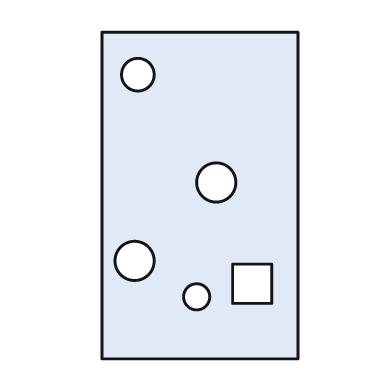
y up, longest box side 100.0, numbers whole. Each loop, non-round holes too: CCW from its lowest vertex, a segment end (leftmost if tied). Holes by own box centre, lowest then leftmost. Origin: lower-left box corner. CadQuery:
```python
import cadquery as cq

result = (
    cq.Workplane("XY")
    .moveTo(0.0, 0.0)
    .lineTo(60.0, 0.0)
    .lineTo(60.0, 100.0)
    .lineTo(0.0, 100.0)
    .close()
    .moveTo(29.0, 19.0)
    .circle(4.0)
    .moveTo(40.0, 17.0)
    .lineTo(52.0, 17.0)
    .lineTo(52.0, 29.0)
    .lineTo(40.0, 29.0)
    .close()
    .moveTo(10.0, 30.0)
    .circle(6.0)
    .moveTo(35.0, 54.0)
    .circle(6.0)
    .moveTo(11.0, 87.0)
    .circle(5.0)
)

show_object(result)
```